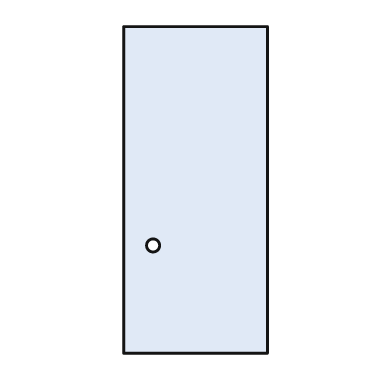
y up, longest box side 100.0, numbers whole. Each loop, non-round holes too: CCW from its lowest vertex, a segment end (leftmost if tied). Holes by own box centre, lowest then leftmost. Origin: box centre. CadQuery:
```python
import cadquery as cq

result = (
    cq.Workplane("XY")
    .moveTo(-22.0, -50.0)
    .lineTo(22.0, -50.0)
    .lineTo(22.0, 50.0)
    .lineTo(-22.0, 50.0)
    .close()
    .moveTo(-13.0, -17.0)
    .circle(2.0)
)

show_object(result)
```